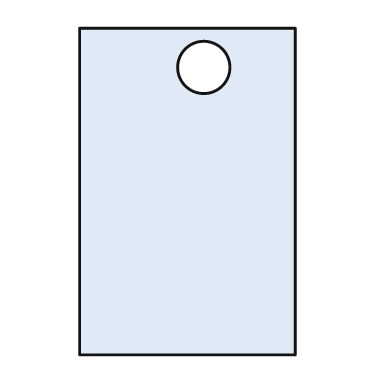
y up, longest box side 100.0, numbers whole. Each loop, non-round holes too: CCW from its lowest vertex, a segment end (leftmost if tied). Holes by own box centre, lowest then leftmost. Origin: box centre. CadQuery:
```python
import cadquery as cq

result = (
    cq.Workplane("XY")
    .moveTo(-33.0, -50.0)
    .lineTo(33.0, -50.0)
    .lineTo(33.0, 50.0)
    .lineTo(-33.0, 50.0)
    .close()
    .moveTo(5.0, 38.0)
    .circle(8.0)
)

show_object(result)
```